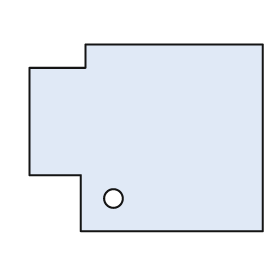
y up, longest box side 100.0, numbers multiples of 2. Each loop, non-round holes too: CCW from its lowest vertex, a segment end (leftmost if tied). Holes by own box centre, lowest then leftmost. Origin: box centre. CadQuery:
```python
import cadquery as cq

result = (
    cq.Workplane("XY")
    .moveTo(-28.0, -40.0)
    .lineTo(50.0, -40.0)
    .lineTo(50.0, 40.0)
    .lineTo(-26.0, 40.0)
    .lineTo(-26.0, 30.0)
    .lineTo(-50.0, 30.0)
    .lineTo(-50.0, -16.0)
    .lineTo(-28.0, -16.0)
    .close()
    .moveTo(-14.0, -26.0)
    .circle(4.0)
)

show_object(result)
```